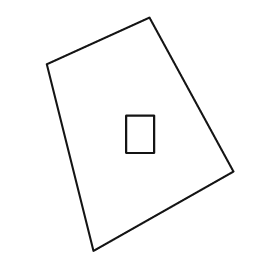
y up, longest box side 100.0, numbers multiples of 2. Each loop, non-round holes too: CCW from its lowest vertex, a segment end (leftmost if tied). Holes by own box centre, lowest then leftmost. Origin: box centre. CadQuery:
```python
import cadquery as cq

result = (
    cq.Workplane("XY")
    .moveTo(-20.0, -50.0)
    .lineTo(40.0, -16.0)
    .lineTo(4.0, 50.0)
    .lineTo(-40.0, 30.0)
    .close()
    .moveTo(-6.0, -8.0)
    .lineTo(6.0, -8.0)
    .lineTo(6.0, 8.0)
    .lineTo(-6.0, 8.0)
    .close()
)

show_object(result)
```